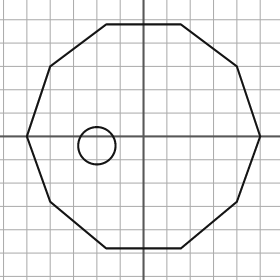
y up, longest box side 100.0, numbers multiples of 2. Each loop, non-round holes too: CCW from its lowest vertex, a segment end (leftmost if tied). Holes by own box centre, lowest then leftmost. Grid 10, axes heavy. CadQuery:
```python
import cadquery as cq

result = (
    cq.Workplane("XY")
    .moveTo(-16.0, -48.0)
    .lineTo(16.0, -48.0)
    .lineTo(40.0, -28.0)
    .lineTo(50.0, 0.0)
    .lineTo(40.0, 30.0)
    .lineTo(16.0, 48.0)
    .lineTo(-16.0, 48.0)
    .lineTo(-40.0, 30.0)
    .lineTo(-50.0, 0.0)
    .lineTo(-40.0, -28.0)
    .close()
    .moveTo(-20.0, -4.0)
    .circle(8.0)
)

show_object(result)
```